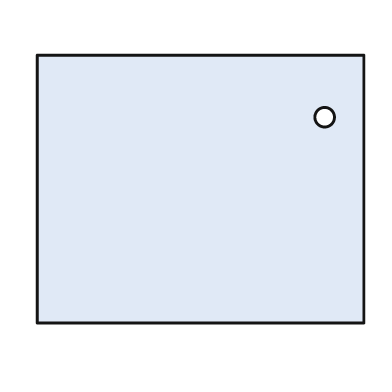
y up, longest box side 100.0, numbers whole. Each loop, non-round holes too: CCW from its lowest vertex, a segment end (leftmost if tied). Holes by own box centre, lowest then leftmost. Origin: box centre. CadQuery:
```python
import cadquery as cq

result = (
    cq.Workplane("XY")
    .moveTo(-50.0, -41.0)
    .lineTo(50.0, -41.0)
    .lineTo(50.0, 41.0)
    .lineTo(-50.0, 41.0)
    .close()
    .moveTo(38.0, 22.0)
    .circle(3.0)
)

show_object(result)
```